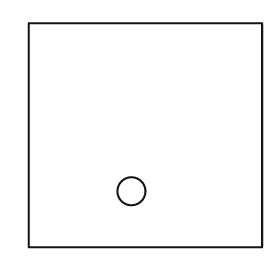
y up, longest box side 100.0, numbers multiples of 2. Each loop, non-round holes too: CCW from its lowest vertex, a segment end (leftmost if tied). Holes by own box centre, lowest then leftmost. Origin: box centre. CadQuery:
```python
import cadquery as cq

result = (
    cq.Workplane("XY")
    .moveTo(-50.0, -48.0)
    .lineTo(50.0, -48.0)
    .lineTo(50.0, 48.0)
    .lineTo(-50.0, 48.0)
    .close()
    .moveTo(-6.0, -24.0)
    .circle(6.0)
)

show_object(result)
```